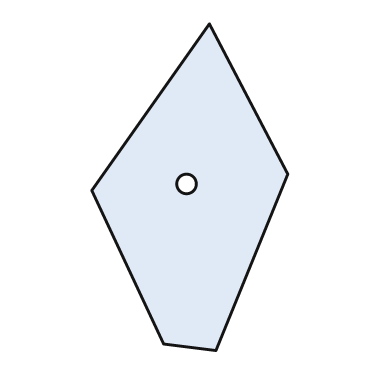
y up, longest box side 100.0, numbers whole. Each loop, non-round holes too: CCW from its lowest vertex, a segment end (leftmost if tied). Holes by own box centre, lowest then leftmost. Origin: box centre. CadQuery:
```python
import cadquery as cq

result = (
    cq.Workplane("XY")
    .moveTo(8.0, -50.0)
    .lineTo(30.0, 4.0)
    .lineTo(6.0, 50.0)
    .lineTo(-30.0, -1.0)
    .lineTo(-8.0, -48.0)
    .close()
    .moveTo(-1.0, 1.0)
    .circle(3.0)
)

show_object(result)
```